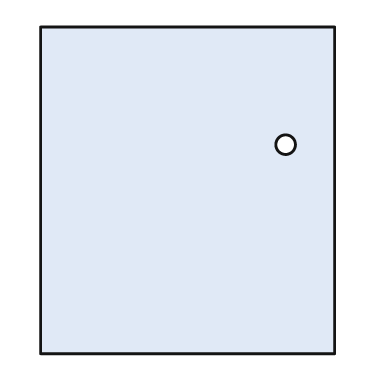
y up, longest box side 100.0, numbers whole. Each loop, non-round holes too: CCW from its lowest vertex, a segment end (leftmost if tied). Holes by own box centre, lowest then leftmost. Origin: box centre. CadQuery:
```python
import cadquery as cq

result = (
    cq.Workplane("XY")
    .moveTo(-45.0, -50.0)
    .lineTo(45.0, -50.0)
    .lineTo(45.0, 50.0)
    .lineTo(-45.0, 50.0)
    .close()
    .moveTo(30.0, 14.0)
    .circle(3.0)
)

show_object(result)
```